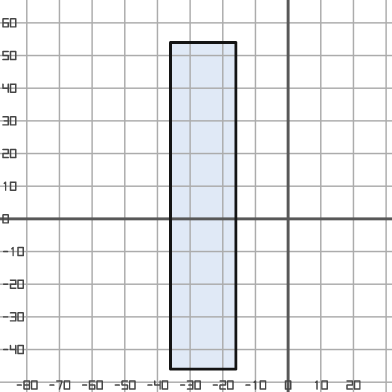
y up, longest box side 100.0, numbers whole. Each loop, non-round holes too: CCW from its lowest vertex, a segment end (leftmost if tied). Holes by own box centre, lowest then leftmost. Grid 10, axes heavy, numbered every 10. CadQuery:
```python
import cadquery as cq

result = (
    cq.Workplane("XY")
    .moveTo(-36.0, -46.0)
    .lineTo(-16.0, -46.0)
    .lineTo(-16.0, 54.0)
    .lineTo(-36.0, 54.0)
    .close()
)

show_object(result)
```